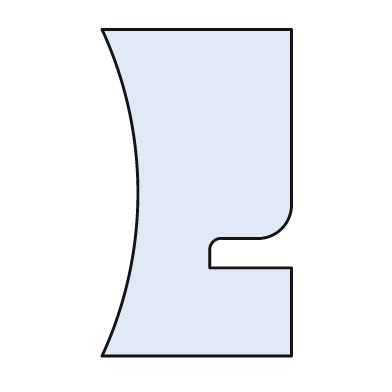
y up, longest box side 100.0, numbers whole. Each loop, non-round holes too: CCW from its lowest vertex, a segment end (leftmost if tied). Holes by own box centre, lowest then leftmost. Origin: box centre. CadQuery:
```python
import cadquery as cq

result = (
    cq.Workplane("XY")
    .moveTo(-29.0, -50.0)
    .lineTo(29.0, -50.0)
    .lineTo(29.0, -23.0)
    .lineTo(4.0, -23.0)
    .lineTo(4.0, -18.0)
    .threePointArc((5.0, -15.0), (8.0, -14.0))
    .lineTo(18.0, -14.0)
    .threePointArc((26.0, -11.0), (29.0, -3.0))
    .lineTo(29.0, 50.0)
    .lineTo(-29.0, 50.0)
    .threePointArc((-18.0, 0.0), (-29.0, -50.0))
    .close()
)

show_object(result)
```